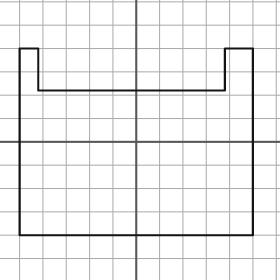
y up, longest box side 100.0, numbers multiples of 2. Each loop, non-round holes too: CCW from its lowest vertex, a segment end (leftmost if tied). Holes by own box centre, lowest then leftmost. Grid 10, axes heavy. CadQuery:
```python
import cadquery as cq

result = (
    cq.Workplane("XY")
    .moveTo(-50.0, -40.0)
    .lineTo(50.0, -40.0)
    .lineTo(50.0, 40.0)
    .lineTo(38.0, 40.0)
    .lineTo(38.0, 22.0)
    .lineTo(-42.0, 22.0)
    .lineTo(-42.0, 40.0)
    .lineTo(-50.0, 40.0)
    .close()
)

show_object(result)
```